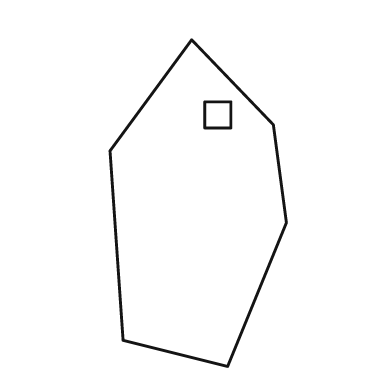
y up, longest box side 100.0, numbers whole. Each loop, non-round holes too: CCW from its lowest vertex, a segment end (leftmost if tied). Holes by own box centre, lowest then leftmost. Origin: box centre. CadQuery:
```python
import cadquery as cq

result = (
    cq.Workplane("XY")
    .moveTo(9.0, -50.0)
    .lineTo(27.0, -6.0)
    .lineTo(23.0, 24.0)
    .lineTo(-2.0, 50.0)
    .lineTo(-27.0, 16.0)
    .lineTo(-23.0, -42.0)
    .close()
    .moveTo(2.0, 23.0)
    .lineTo(10.0, 23.0)
    .lineTo(10.0, 31.0)
    .lineTo(2.0, 31.0)
    .close()
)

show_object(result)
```